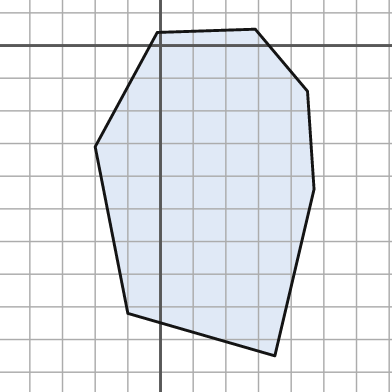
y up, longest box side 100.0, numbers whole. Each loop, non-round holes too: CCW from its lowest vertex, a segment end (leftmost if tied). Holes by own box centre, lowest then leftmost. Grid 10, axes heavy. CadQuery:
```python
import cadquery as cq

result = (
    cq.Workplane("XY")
    .moveTo(35.0, -95.0)
    .lineTo(47.0, -44.0)
    .lineTo(45.0, -14.0)
    .lineTo(29.0, 5.0)
    .lineTo(-1.0, 4.0)
    .lineTo(-20.0, -31.0)
    .lineTo(-10.0, -82.0)
    .close()
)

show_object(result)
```